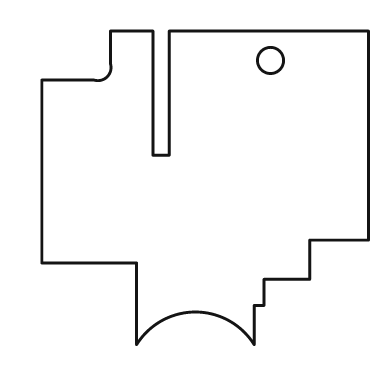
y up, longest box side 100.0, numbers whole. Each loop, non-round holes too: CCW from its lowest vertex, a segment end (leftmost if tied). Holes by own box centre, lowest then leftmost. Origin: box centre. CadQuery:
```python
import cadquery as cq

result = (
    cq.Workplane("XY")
    .moveTo(-21.0, -48.0)
    .threePointArc((-3.0, -38.0), (15.0, -48.0))
    .lineTo(15.0, -36.0)
    .lineTo(18.0, -36.0)
    .lineTo(18.0, -28.0)
    .lineTo(32.0, -28.0)
    .lineTo(32.0, -16.0)
    .lineTo(50.0, -16.0)
    .lineTo(50.0, 48.0)
    .lineTo(-11.0, 48.0)
    .lineTo(-11.0, 10.0)
    .lineTo(-16.0, 10.0)
    .lineTo(-16.0, 48.0)
    .lineTo(-29.0, 48.0)
    .lineTo(-29.0, 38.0)
    .threePointArc((-30.0, 34.0), (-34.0, 33.0))
    .lineTo(-50.0, 33.0)
    .lineTo(-50.0, -23.0)
    .lineTo(-21.0, -23.0)
    .close()
    .moveTo(20.0, 39.0)
    .circle(4.0)
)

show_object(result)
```